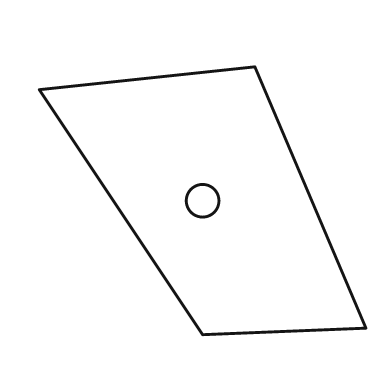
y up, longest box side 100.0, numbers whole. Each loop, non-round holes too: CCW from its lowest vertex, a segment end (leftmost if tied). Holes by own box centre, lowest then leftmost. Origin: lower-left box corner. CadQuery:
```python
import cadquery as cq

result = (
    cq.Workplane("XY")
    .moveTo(50.0, 0.0)
    .lineTo(100.0, 2.0)
    .lineTo(66.0, 82.0)
    .lineTo(0.0, 75.0)
    .close()
    .moveTo(50.0, 41.0)
    .circle(5.0)
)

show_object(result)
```